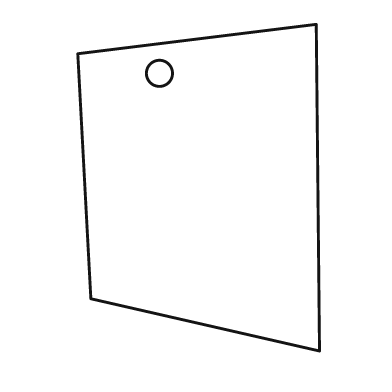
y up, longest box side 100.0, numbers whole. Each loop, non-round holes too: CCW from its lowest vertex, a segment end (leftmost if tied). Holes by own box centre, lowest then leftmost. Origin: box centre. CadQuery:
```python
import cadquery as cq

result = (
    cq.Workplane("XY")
    .moveTo(37.0, -50.0)
    .lineTo(36.0, 50.0)
    .lineTo(-37.0, 41.0)
    .lineTo(-33.0, -34.0)
    .close()
    .moveTo(-12.0, 35.0)
    .circle(4.0)
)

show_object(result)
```